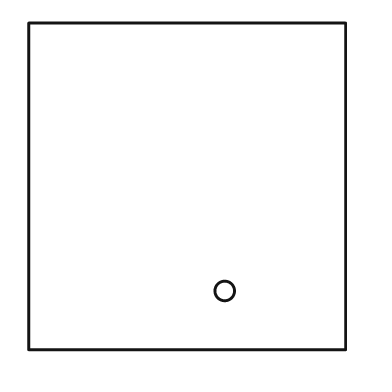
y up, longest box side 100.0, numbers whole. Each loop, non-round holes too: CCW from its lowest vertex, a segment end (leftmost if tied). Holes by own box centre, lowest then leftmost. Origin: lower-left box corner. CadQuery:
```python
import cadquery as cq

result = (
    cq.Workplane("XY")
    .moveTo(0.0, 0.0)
    .lineTo(97.0, 0.0)
    .lineTo(97.0, 100.0)
    .lineTo(0.0, 100.0)
    .close()
    .moveTo(60.0, 18.0)
    .circle(3.0)
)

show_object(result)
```